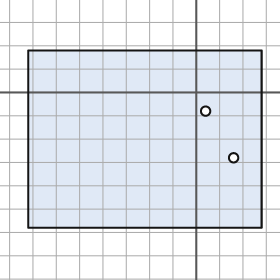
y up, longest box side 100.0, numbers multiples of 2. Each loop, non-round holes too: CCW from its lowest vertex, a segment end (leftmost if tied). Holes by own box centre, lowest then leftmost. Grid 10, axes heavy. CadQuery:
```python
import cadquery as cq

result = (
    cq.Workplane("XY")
    .moveTo(-72.0, -58.0)
    .lineTo(28.0, -58.0)
    .lineTo(28.0, 18.0)
    .lineTo(-72.0, 18.0)
    .close()
    .moveTo(16.0, -28.0)
    .circle(2.0)
    .moveTo(4.0, -8.0)
    .circle(2.0)
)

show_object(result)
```